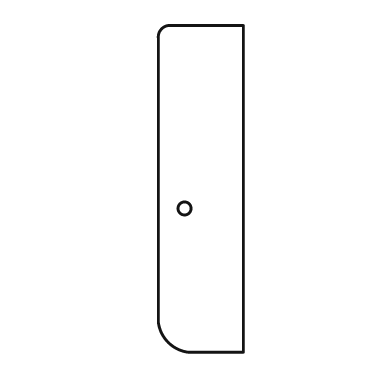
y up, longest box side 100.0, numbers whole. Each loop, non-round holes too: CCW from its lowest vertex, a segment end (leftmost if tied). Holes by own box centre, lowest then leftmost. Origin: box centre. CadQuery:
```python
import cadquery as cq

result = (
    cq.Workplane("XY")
    .moveTo(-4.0, -50.0)
    .lineTo(13.0, -50.0)
    .lineTo(13.0, 50.0)
    .lineTo(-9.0, 50.0)
    .threePointArc((-12.0, 49.0), (-13.0, 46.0))
    .lineTo(-13.0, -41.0)
    .threePointArc((-10.0, -47.0), (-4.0, -50.0))
    .close()
    .moveTo(-5.0, -6.0)
    .circle(2.0)
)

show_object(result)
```